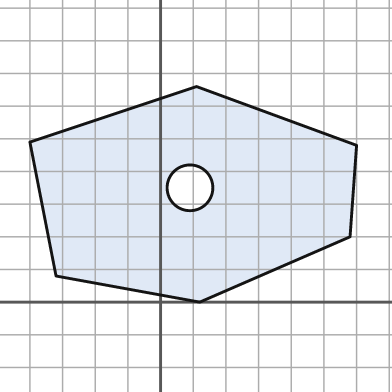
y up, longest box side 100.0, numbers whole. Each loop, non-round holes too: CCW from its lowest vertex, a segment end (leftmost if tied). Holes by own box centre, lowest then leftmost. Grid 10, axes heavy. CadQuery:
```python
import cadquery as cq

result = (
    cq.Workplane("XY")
    .moveTo(12.0, 0.0)
    .lineTo(58.0, 20.0)
    .lineTo(60.0, 48.0)
    .lineTo(11.0, 66.0)
    .lineTo(-40.0, 49.0)
    .lineTo(-32.0, 8.0)
    .close()
    .moveTo(9.0, 35.0)
    .circle(7.0)
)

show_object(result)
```